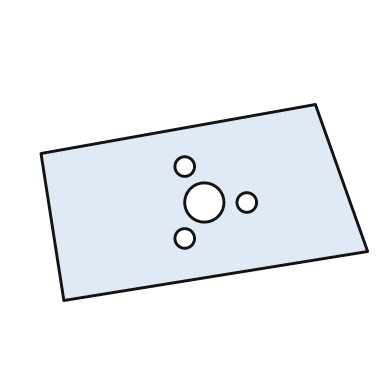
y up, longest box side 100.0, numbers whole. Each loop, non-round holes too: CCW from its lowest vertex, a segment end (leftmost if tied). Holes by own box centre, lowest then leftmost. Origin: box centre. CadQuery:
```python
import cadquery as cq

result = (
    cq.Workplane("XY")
    .moveTo(-43.0, -30.0)
    .lineTo(50.0, -15.0)
    .lineTo(34.0, 30.0)
    .lineTo(-50.0, 15.0)
    .close()
    .moveTo(-6.0, -11.0)
    .circle(3.0)
    .moveTo(0.0, 0.0)
    .circle(6.0)
    .moveTo(13.0, 0.0)
    .circle(3.0)
    .moveTo(-6.0, 11.0)
    .circle(3.0)
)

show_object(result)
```